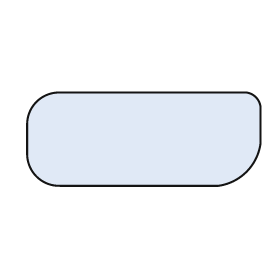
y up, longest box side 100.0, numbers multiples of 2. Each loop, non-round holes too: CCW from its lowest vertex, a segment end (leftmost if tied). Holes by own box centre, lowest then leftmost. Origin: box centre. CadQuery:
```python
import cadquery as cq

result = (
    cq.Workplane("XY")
    .moveTo(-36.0, -20.0)
    .lineTo(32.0, -20.0)
    .threePointArc((44.0, -14.0), (50.0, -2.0))
    .lineTo(50.0, 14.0)
    .threePointArc((48.0, 18.0), (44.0, 20.0))
    .lineTo(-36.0, 20.0)
    .threePointArc((-46.0, 16.0), (-50.0, 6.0))
    .lineTo(-50.0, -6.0)
    .threePointArc((-46.0, -16.0), (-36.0, -20.0))
    .close()
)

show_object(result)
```